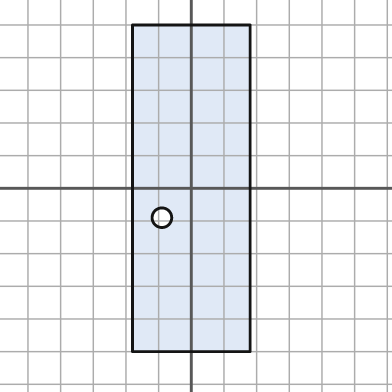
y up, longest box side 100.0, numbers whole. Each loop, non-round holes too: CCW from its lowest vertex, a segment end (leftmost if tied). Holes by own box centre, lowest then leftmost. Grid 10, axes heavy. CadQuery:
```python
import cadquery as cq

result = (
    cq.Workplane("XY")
    .moveTo(-18.0, -50.0)
    .lineTo(18.0, -50.0)
    .lineTo(18.0, 50.0)
    .lineTo(-18.0, 50.0)
    .close()
    .moveTo(-9.0, -9.0)
    .circle(3.0)
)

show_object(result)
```